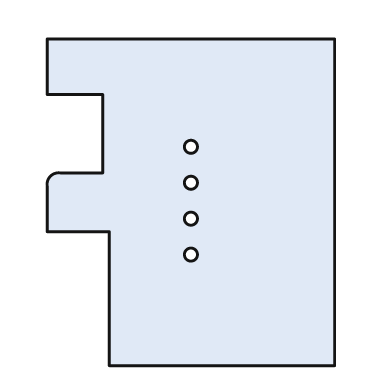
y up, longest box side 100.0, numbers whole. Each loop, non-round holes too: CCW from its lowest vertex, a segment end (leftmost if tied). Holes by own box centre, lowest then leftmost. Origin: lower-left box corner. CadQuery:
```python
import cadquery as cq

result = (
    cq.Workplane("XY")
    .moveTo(19.0, 0.0)
    .lineTo(88.0, 0.0)
    .lineTo(88.0, 100.0)
    .lineTo(0.0, 100.0)
    .lineTo(0.0, 83.0)
    .lineTo(17.0, 83.0)
    .lineTo(17.0, 59.0)
    .lineTo(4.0, 59.0)
    .threePointArc((1.0, 58.0), (0.0, 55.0))
    .lineTo(0.0, 41.0)
    .lineTo(19.0, 41.0)
    .close()
    .moveTo(44.0, 34.0)
    .circle(2.0)
    .moveTo(44.0, 45.0)
    .circle(2.0)
    .moveTo(44.0, 56.0)
    .circle(2.0)
    .moveTo(44.0, 67.0)
    .circle(2.0)
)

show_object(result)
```